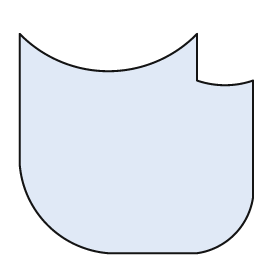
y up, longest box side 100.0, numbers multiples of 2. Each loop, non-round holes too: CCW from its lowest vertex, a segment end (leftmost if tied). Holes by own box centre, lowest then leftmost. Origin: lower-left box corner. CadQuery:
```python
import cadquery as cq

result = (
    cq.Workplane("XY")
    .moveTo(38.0, 0.0)
    .lineTo(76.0, 0.0)
    .threePointArc((92.0, 8.0), (100.0, 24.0))
    .lineTo(100.0, 74.0)
    .threePointArc((88.0, 72.0), (76.0, 74.0))
    .lineTo(76.0, 94.0)
    .threePointArc((38.0, 78.0), (0.0, 94.0))
    .lineTo(0.0, 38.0)
    .threePointArc((12.0, 12.0), (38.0, 0.0))
    .close()
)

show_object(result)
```